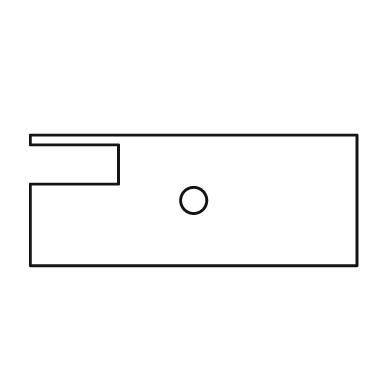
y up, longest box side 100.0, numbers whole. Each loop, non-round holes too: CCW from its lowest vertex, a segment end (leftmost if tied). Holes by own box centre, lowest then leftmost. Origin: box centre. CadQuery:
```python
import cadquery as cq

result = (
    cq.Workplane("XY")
    .moveTo(-50.0, -20.0)
    .lineTo(50.0, -20.0)
    .lineTo(50.0, 20.0)
    .lineTo(-50.0, 20.0)
    .lineTo(-50.0, 17.0)
    .lineTo(-23.0, 17.0)
    .lineTo(-23.0, 5.0)
    .lineTo(-50.0, 5.0)
    .close()
    .moveTo(0.0, 0.0)
    .circle(4.0)
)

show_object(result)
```